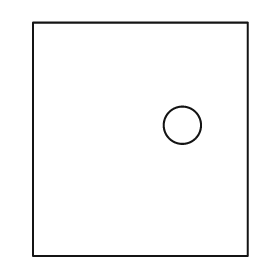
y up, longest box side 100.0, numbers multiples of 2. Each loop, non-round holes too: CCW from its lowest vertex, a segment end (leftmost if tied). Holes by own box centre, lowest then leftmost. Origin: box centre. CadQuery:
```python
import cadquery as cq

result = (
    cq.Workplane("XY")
    .moveTo(-46.0, -50.0)
    .lineTo(46.0, -50.0)
    .lineTo(46.0, 50.0)
    .lineTo(-46.0, 50.0)
    .close()
    .moveTo(18.0, 6.0)
    .circle(8.0)
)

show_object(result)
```